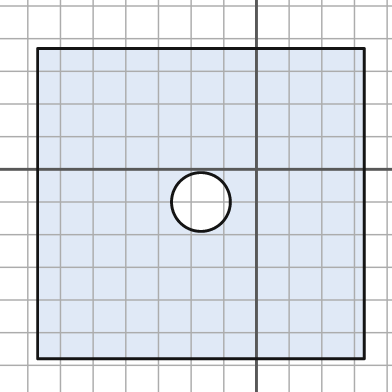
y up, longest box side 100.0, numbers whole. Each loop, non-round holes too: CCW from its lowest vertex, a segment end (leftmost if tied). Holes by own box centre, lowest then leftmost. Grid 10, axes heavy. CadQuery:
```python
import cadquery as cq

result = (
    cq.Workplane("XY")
    .moveTo(-67.0, -58.0)
    .lineTo(33.0, -58.0)
    .lineTo(33.0, 37.0)
    .lineTo(-67.0, 37.0)
    .close()
    .moveTo(-17.0, -10.0)
    .circle(9.0)
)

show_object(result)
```